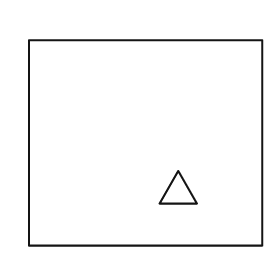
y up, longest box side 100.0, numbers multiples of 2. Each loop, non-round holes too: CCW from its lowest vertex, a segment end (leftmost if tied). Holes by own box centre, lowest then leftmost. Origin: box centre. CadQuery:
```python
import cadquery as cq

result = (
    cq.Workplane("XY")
    .moveTo(-50.0, -44.0)
    .lineTo(50.0, -44.0)
    .lineTo(50.0, 44.0)
    .lineTo(-50.0, 44.0)
    .close()
    .moveTo(6.0, -26.0)
    .lineTo(22.0, -26.0)
    .lineTo(14.0, -12.0)
    .close()
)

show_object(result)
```